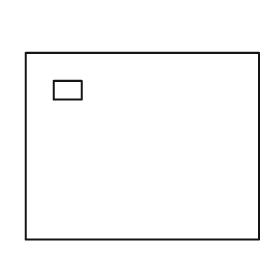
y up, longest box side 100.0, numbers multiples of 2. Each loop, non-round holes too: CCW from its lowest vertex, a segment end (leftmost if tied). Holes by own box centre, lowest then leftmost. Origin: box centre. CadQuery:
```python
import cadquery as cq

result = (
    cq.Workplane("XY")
    .moveTo(-50.0, -40.0)
    .lineTo(50.0, -40.0)
    .lineTo(50.0, 40.0)
    .lineTo(-50.0, 40.0)
    .close()
    .moveTo(-38.0, 20.0)
    .lineTo(-26.0, 20.0)
    .lineTo(-26.0, 28.0)
    .lineTo(-38.0, 28.0)
    .close()
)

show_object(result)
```